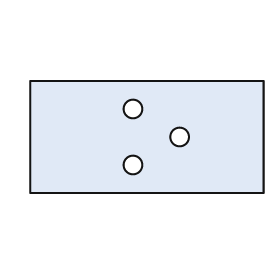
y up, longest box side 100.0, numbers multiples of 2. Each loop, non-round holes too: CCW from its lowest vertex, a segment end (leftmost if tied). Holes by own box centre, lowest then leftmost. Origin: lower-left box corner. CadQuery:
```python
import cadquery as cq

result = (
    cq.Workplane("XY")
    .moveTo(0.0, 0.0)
    .lineTo(100.0, 0.0)
    .lineTo(100.0, 48.0)
    .lineTo(0.0, 48.0)
    .close()
    .moveTo(44.0, 12.0)
    .circle(4.0)
    .moveTo(64.0, 24.0)
    .circle(4.0)
    .moveTo(44.0, 36.0)
    .circle(4.0)
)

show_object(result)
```